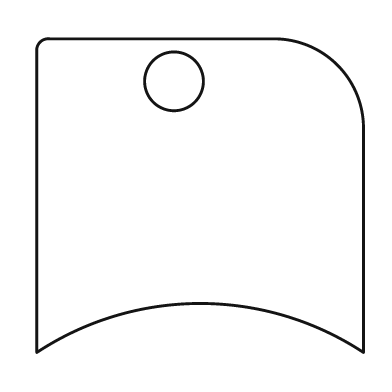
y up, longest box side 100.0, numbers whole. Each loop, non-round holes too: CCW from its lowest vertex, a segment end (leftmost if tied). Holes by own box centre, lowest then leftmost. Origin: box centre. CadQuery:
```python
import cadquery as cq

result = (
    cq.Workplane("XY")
    .moveTo(-50.0, -48.0)
    .threePointArc((0.0, -33.0), (50.0, -48.0))
    .lineTo(50.0, 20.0)
    .threePointArc((42.0, 40.0), (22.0, 48.0))
    .lineTo(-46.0, 48.0)
    .threePointArc((-49.0, 47.0), (-50.0, 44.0))
    .close()
    .moveTo(-8.0, 35.0)
    .circle(9.0)
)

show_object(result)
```